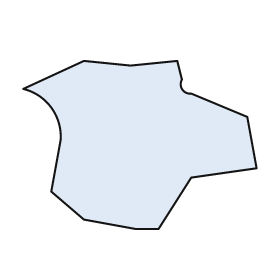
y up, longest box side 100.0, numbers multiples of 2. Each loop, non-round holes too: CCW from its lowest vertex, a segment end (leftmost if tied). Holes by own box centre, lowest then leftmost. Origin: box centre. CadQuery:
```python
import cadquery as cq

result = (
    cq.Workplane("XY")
    .moveTo(-2.0, -36.0)
    .lineTo(8.0, -36.0)
    .lineTo(22.0, -14.0)
    .lineTo(50.0, -10.0)
    .lineTo(46.0, 12.0)
    .lineTo(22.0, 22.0)
    .threePointArc((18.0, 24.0), (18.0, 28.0))
    .lineTo(16.0, 36.0)
    .lineTo(-4.0, 34.0)
    .lineTo(-24.0, 36.0)
    .lineTo(-50.0, 24.0)
    .threePointArc((-38.0, 16.0), (-34.0, 2.0))
    .lineTo(-38.0, -20.0)
    .lineTo(-24.0, -32.0)
    .close()
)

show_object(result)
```